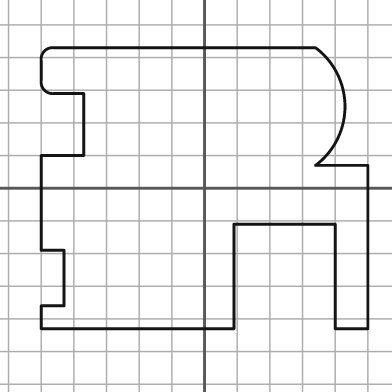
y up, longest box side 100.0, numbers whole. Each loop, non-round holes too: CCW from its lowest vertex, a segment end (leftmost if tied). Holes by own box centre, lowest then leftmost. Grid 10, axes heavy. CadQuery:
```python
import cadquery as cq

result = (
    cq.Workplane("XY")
    .moveTo(-50.0, -43.0)
    .lineTo(9.0, -43.0)
    .lineTo(9.0, -11.0)
    .lineTo(40.0, -11.0)
    .lineTo(40.0, -43.0)
    .lineTo(50.0, -43.0)
    .lineTo(50.0, 7.0)
    .lineTo(34.0, 7.0)
    .threePointArc((43.0, 25.0), (34.0, 43.0))
    .lineTo(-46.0, 43.0)
    .threePointArc((-49.0, 42.0), (-50.0, 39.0))
    .lineTo(-50.0, 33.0)
    .threePointArc((-49.0, 30.0), (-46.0, 29.0))
    .lineTo(-37.0, 29.0)
    .lineTo(-37.0, 10.0)
    .lineTo(-50.0, 10.0)
    .lineTo(-50.0, -19.0)
    .lineTo(-43.0, -19.0)
    .lineTo(-43.0, -36.0)
    .lineTo(-50.0, -36.0)
    .close()
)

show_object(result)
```